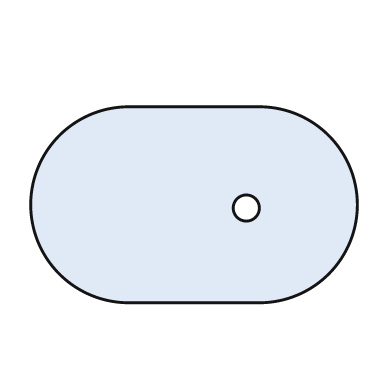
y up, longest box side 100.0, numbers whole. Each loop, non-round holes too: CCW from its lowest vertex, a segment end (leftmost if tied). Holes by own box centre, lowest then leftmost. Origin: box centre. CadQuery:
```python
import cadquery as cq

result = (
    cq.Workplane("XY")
    .moveTo(-20.0, -30.0)
    .lineTo(20.0, -30.0)
    .threePointArc((50.0, 0.0), (20.0, 30.0))
    .lineTo(-20.0, 30.0)
    .threePointArc((-50.0, 0.0), (-20.0, -30.0))
    .close()
    .moveTo(16.0, -1.0)
    .circle(4.0)
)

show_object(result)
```